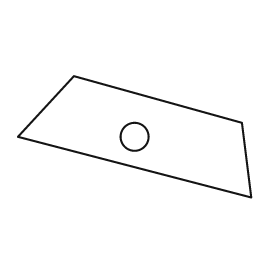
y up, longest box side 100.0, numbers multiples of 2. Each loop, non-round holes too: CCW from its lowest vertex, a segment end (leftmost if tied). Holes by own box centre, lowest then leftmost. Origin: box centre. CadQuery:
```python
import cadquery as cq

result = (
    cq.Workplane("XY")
    .moveTo(50.0, -26.0)
    .lineTo(46.0, 6.0)
    .lineTo(-26.0, 26.0)
    .lineTo(-50.0, 0.0)
    .close()
    .moveTo(0.0, 0.0)
    .circle(6.0)
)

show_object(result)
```